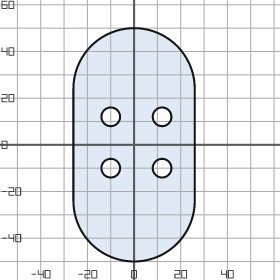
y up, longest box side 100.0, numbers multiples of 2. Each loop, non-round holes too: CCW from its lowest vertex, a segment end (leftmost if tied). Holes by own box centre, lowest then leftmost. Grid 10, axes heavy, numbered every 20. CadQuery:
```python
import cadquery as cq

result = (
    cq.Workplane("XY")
    .moveTo(-26.0, -24.0)
    .threePointArc((0.0, -50.0), (26.0, -24.0))
    .lineTo(26.0, 24.0)
    .threePointArc((0.0, 50.0), (-26.0, 24.0))
    .close()
    .moveTo(-10.0, -10.0)
    .circle(4.0)
    .moveTo(12.0, -10.0)
    .circle(4.0)
    .moveTo(-10.0, 12.0)
    .circle(4.0)
    .moveTo(12.0, 12.0)
    .circle(4.0)
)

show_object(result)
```